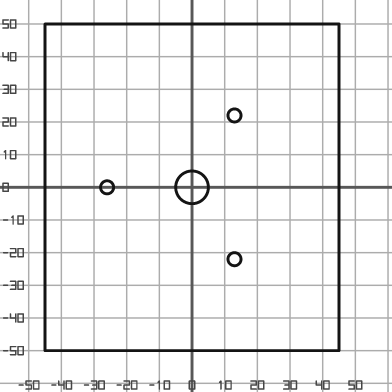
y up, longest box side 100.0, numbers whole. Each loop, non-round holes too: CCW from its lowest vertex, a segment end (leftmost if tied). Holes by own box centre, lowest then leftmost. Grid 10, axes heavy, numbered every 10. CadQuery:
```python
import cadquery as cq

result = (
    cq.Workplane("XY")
    .moveTo(-45.0, -50.0)
    .lineTo(45.0, -50.0)
    .lineTo(45.0, 50.0)
    .lineTo(-45.0, 50.0)
    .close()
    .moveTo(13.0, -22.0)
    .circle(2.0)
    .moveTo(-26.0, 0.0)
    .circle(2.0)
    .moveTo(0.0, 0.0)
    .circle(5.0)
    .moveTo(13.0, 22.0)
    .circle(2.0)
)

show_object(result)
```